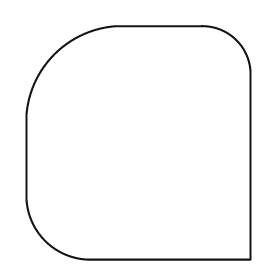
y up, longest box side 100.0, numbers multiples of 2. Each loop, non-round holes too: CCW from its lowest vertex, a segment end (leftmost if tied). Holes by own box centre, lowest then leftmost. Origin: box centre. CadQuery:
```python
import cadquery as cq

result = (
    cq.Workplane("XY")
    .moveTo(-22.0, -50.0)
    .lineTo(48.0, -50.0)
    .lineTo(48.0, 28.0)
    .threePointArc((42.0, 44.0), (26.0, 50.0))
    .lineTo(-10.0, 50.0)
    .threePointArc((-36.0, 38.0), (-48.0, 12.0))
    .lineTo(-48.0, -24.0)
    .threePointArc((-40.0, -42.0), (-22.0, -50.0))
    .close()
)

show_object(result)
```